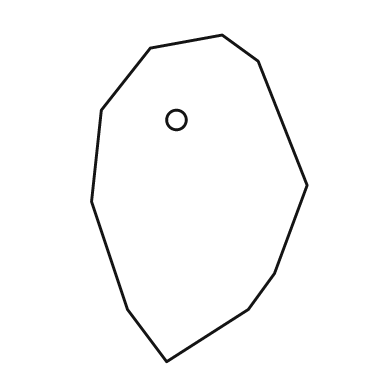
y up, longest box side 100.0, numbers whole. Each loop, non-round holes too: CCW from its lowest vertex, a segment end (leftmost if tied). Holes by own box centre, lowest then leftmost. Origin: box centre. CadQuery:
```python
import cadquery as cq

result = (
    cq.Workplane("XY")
    .moveTo(-10.0, -50.0)
    .lineTo(15.0, -34.0)
    .lineTo(23.0, -23.0)
    .lineTo(33.0, 4.0)
    .lineTo(18.0, 42.0)
    .lineTo(7.0, 50.0)
    .lineTo(-15.0, 46.0)
    .lineTo(-30.0, 27.0)
    .lineTo(-33.0, -1.0)
    .lineTo(-22.0, -34.0)
    .close()
    .moveTo(-7.0, 24.0)
    .circle(3.0)
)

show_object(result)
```